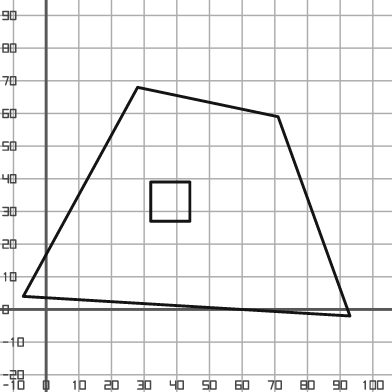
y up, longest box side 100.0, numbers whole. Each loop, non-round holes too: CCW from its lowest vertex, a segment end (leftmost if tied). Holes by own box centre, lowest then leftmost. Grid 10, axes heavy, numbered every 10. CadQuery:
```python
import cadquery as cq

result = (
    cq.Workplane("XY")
    .moveTo(93.0, -2.0)
    .lineTo(71.0, 59.0)
    .lineTo(28.0, 68.0)
    .lineTo(-7.0, 4.0)
    .close()
    .moveTo(32.0, 27.0)
    .lineTo(44.0, 27.0)
    .lineTo(44.0, 39.0)
    .lineTo(32.0, 39.0)
    .close()
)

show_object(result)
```